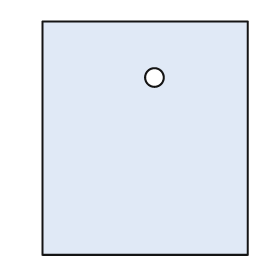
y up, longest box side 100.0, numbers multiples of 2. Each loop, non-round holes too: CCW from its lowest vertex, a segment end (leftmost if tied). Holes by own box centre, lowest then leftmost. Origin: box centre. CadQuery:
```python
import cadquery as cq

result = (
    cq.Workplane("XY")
    .moveTo(-44.0, -50.0)
    .lineTo(44.0, -50.0)
    .lineTo(44.0, 50.0)
    .lineTo(-44.0, 50.0)
    .close()
    .moveTo(4.0, 26.0)
    .circle(4.0)
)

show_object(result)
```